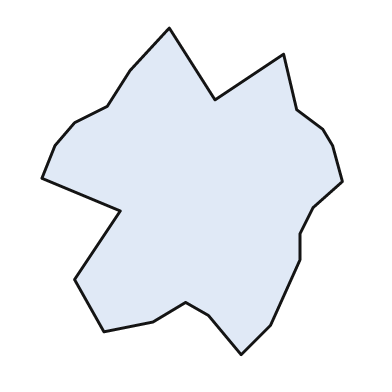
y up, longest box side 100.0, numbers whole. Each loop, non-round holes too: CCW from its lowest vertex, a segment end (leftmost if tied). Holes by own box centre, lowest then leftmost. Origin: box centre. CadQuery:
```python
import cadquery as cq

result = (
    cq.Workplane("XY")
    .moveTo(15.0, -50.0)
    .lineTo(24.0, -41.0)
    .lineTo(33.0, -21.0)
    .lineTo(33.0, -13.0)
    .lineTo(37.0, -5.0)
    .lineTo(46.0, 3.0)
    .lineTo(43.0, 14.0)
    .lineTo(40.0, 19.0)
    .lineTo(32.0, 25.0)
    .lineTo(28.0, 42.0)
    .lineTo(7.0, 28.0)
    .lineTo(-7.0, 50.0)
    .lineTo(-19.0, 37.0)
    .lineTo(-26.0, 26.0)
    .lineTo(-36.0, 21.0)
    .lineTo(-42.0, 14.0)
    .lineTo(-46.0, 4.0)
    .lineTo(-22.0, -6.0)
    .lineTo(-36.0, -27.0)
    .lineTo(-27.0, -43.0)
    .lineTo(-12.0, -40.0)
    .lineTo(-2.0, -34.0)
    .lineTo(5.0, -38.0)
    .close()
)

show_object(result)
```